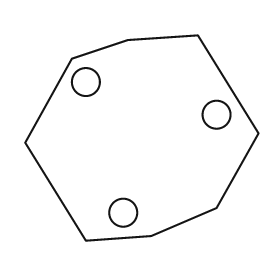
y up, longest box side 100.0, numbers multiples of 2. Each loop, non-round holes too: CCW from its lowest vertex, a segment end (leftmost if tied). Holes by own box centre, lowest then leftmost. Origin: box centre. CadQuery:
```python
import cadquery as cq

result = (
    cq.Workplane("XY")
    .moveTo(-24.0, -44.0)
    .lineTo(4.0, -42.0)
    .lineTo(32.0, -30.0)
    .lineTo(50.0, 2.0)
    .lineTo(24.0, 44.0)
    .lineTo(-6.0, 42.0)
    .lineTo(-30.0, 34.0)
    .lineTo(-50.0, -2.0)
    .close()
    .moveTo(-8.0, -32.0)
    .circle(6.0)
    .moveTo(32.0, 10.0)
    .circle(6.0)
    .moveTo(-24.0, 24.0)
    .circle(6.0)
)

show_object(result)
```